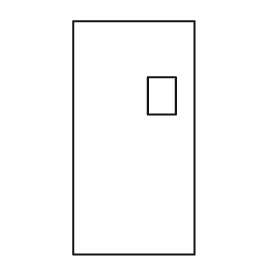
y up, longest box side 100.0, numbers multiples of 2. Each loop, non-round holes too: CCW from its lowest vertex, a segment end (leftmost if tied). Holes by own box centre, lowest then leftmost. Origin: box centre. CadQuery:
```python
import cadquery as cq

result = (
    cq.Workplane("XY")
    .moveTo(-26.0, -50.0)
    .lineTo(26.0, -50.0)
    .lineTo(26.0, 50.0)
    .lineTo(-26.0, 50.0)
    .close()
    .moveTo(6.0, 10.0)
    .lineTo(18.0, 10.0)
    .lineTo(18.0, 26.0)
    .lineTo(6.0, 26.0)
    .close()
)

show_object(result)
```